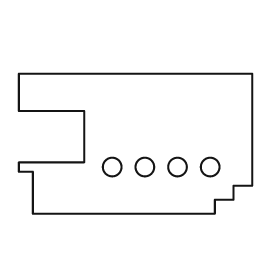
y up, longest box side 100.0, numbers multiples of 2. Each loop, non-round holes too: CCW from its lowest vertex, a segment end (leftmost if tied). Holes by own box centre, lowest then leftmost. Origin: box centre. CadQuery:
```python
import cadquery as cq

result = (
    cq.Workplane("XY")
    .moveTo(-44.0, -30.0)
    .lineTo(34.0, -30.0)
    .lineTo(34.0, -24.0)
    .lineTo(42.0, -24.0)
    .lineTo(42.0, -18.0)
    .lineTo(50.0, -18.0)
    .lineTo(50.0, 30.0)
    .lineTo(-50.0, 30.0)
    .lineTo(-50.0, 14.0)
    .lineTo(-22.0, 14.0)
    .lineTo(-22.0, -8.0)
    .lineTo(-50.0, -8.0)
    .lineTo(-50.0, -12.0)
    .lineTo(-44.0, -12.0)
    .close()
    .moveTo(-10.0, -10.0)
    .circle(4.0)
    .moveTo(4.0, -10.0)
    .circle(4.0)
    .moveTo(18.0, -10.0)
    .circle(4.0)
    .moveTo(32.0, -10.0)
    .circle(4.0)
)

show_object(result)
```